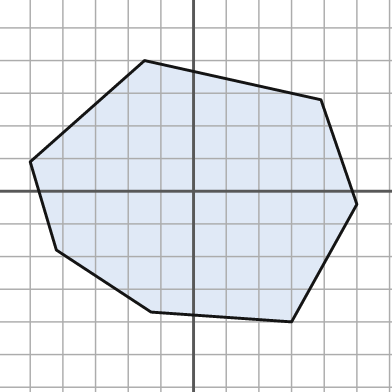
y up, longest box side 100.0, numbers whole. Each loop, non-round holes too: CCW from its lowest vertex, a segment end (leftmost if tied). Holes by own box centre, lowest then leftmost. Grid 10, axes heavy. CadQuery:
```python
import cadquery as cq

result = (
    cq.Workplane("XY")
    .moveTo(30.0, -40.0)
    .lineTo(50.0, -4.0)
    .lineTo(39.0, 28.0)
    .lineTo(-15.0, 40.0)
    .lineTo(-50.0, 9.0)
    .lineTo(-42.0, -18.0)
    .lineTo(-13.0, -37.0)
    .close()
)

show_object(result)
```